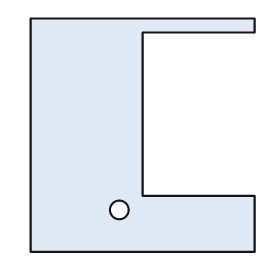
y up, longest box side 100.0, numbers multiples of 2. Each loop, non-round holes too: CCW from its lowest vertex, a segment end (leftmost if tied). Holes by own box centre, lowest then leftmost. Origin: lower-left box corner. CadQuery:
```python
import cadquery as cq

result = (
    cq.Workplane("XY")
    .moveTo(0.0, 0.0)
    .lineTo(96.0, 0.0)
    .lineTo(96.0, 24.0)
    .lineTo(48.0, 24.0)
    .lineTo(48.0, 94.0)
    .lineTo(96.0, 94.0)
    .lineTo(96.0, 100.0)
    .lineTo(0.0, 100.0)
    .close()
    .moveTo(38.0, 18.0)
    .circle(4.0)
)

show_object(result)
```